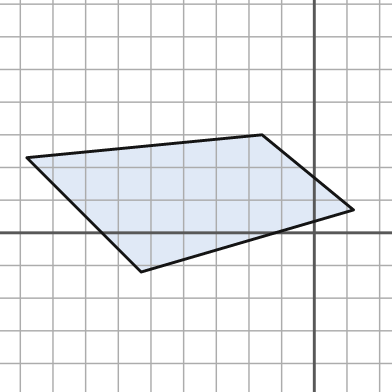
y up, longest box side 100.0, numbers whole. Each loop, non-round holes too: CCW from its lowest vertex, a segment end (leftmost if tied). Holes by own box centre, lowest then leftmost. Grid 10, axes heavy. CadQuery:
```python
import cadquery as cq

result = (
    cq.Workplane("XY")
    .moveTo(-53.0, -12.0)
    .lineTo(12.0, 7.0)
    .lineTo(-16.0, 30.0)
    .lineTo(-88.0, 23.0)
    .close()
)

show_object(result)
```